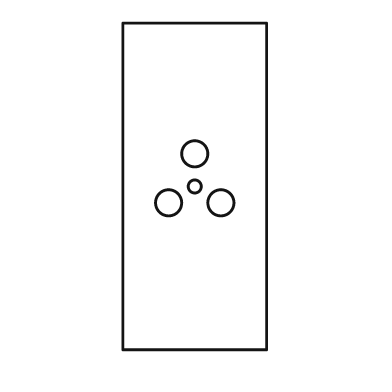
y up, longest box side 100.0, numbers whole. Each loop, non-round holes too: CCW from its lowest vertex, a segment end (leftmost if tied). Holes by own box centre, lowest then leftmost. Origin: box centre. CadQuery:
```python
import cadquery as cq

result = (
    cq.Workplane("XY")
    .moveTo(-22.0, -50.0)
    .lineTo(22.0, -50.0)
    .lineTo(22.0, 50.0)
    .lineTo(-22.0, 50.0)
    .close()
    .moveTo(-8.0, -5.0)
    .circle(4.0)
    .moveTo(8.0, -5.0)
    .circle(4.0)
    .moveTo(0.0, 0.0)
    .circle(2.0)
    .moveTo(0.0, 10.0)
    .circle(4.0)
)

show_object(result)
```